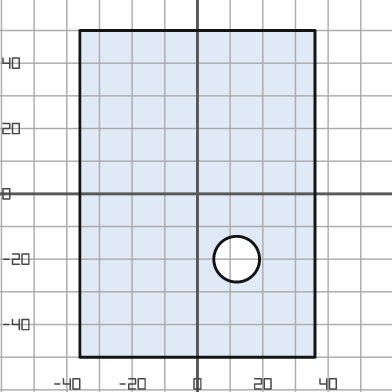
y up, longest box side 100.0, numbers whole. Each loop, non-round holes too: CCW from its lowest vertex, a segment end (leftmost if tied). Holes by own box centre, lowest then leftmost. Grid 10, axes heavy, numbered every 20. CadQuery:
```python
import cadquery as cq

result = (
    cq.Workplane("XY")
    .moveTo(-36.0, -50.0)
    .lineTo(36.0, -50.0)
    .lineTo(36.0, 50.0)
    .lineTo(-36.0, 50.0)
    .close()
    .moveTo(12.0, -20.0)
    .circle(7.0)
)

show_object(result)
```